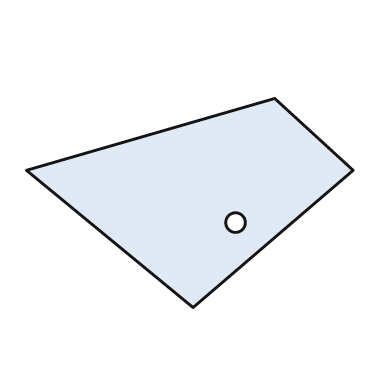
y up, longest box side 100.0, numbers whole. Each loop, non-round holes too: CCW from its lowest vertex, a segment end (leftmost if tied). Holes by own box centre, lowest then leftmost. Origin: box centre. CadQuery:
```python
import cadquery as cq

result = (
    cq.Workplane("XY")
    .moveTo(1.0, -32.0)
    .lineTo(50.0, 10.0)
    .lineTo(26.0, 32.0)
    .lineTo(-50.0, 10.0)
    .close()
    .moveTo(14.0, -6.0)
    .circle(3.0)
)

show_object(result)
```